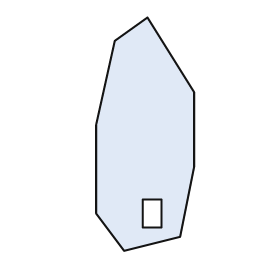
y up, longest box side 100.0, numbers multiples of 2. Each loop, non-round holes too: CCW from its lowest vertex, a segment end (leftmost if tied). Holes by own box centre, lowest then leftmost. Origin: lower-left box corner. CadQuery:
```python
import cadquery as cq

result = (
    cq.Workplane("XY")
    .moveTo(12.0, 0.0)
    .lineTo(36.0, 6.0)
    .lineTo(42.0, 36.0)
    .lineTo(42.0, 68.0)
    .lineTo(22.0, 100.0)
    .lineTo(8.0, 90.0)
    .lineTo(0.0, 54.0)
    .lineTo(0.0, 16.0)
    .close()
    .moveTo(20.0, 10.0)
    .lineTo(28.0, 10.0)
    .lineTo(28.0, 22.0)
    .lineTo(20.0, 22.0)
    .close()
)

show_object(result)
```